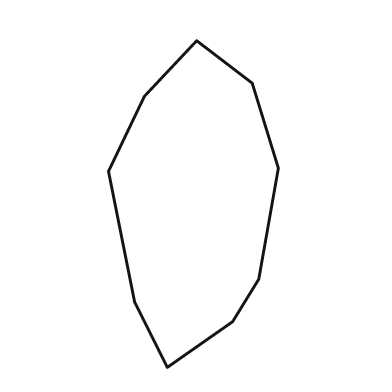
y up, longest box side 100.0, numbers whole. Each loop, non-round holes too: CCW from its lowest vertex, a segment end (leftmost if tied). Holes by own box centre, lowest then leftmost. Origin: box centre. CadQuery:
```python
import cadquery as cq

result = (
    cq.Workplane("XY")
    .moveTo(-8.0, -50.0)
    .lineTo(12.0, -36.0)
    .lineTo(20.0, -23.0)
    .lineTo(26.0, 11.0)
    .lineTo(18.0, 37.0)
    .lineTo(1.0, 50.0)
    .lineTo(-15.0, 33.0)
    .lineTo(-26.0, 10.0)
    .lineTo(-18.0, -30.0)
    .close()
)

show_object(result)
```